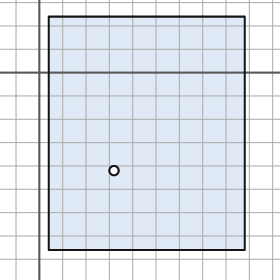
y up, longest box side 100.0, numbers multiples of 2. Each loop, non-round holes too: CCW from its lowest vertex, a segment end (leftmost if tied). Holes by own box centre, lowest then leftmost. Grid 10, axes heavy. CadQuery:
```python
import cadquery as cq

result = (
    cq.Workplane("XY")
    .moveTo(4.0, -76.0)
    .lineTo(88.0, -76.0)
    .lineTo(88.0, 24.0)
    .lineTo(4.0, 24.0)
    .close()
    .moveTo(32.0, -42.0)
    .circle(2.0)
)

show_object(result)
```